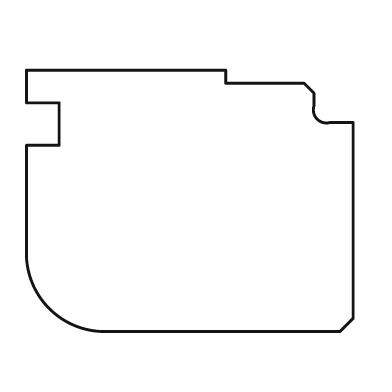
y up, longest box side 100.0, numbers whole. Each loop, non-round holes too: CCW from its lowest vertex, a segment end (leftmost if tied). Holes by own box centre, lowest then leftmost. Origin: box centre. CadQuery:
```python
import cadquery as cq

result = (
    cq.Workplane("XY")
    .moveTo(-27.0, -40.0)
    .lineTo(46.0, -40.0)
    .lineTo(50.0, -36.0)
    .lineTo(50.0, 24.0)
    .lineTo(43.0, 24.0)
    .threePointArc((39.0, 25.0), (38.0, 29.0))
    .lineTo(38.0, 33.0)
    .lineTo(35.0, 36.0)
    .lineTo(11.0, 36.0)
    .lineTo(11.0, 40.0)
    .lineTo(-50.0, 40.0)
    .lineTo(-50.0, 30.0)
    .lineTo(-40.0, 30.0)
    .lineTo(-40.0, 17.0)
    .lineTo(-50.0, 17.0)
    .lineTo(-50.0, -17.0)
    .threePointArc((-43.0, -33.0), (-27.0, -40.0))
    .close()
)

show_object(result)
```